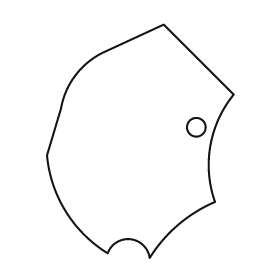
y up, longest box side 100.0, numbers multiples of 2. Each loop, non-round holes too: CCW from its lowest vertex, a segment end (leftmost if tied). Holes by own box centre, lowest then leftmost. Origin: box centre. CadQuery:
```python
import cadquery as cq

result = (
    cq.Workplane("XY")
    .moveTo(4.0, -50.0)
    .threePointArc((16.0, -36.0), (32.0, -26.0))
    .threePointArc((30.0, -2.0), (40.0, 20.0))
    .lineTo(10.0, 50.0)
    .lineTo(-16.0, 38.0)
    .threePointArc((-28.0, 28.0), (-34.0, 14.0))
    .lineTo(-40.0, -6.0)
    .threePointArc((-32.0, -30.0), (-14.0, -48.0))
    .threePointArc((-4.0, -42.0), (4.0, -50.0))
    .close()
    .moveTo(24.0, 6.0)
    .circle(4.0)
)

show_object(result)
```